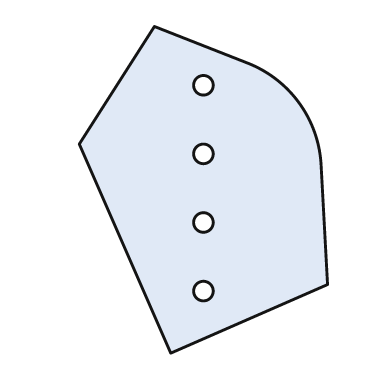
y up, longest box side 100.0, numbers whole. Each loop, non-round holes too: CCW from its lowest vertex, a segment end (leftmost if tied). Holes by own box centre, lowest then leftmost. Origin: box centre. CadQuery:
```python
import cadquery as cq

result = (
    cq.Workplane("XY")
    .moveTo(-10.0, -50.0)
    .lineTo(38.0, -29.0)
    .lineTo(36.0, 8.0)
    .threePointArc((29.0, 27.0), (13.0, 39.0))
    .lineTo(-15.0, 50.0)
    .lineTo(-38.0, 14.0)
    .close()
    .moveTo(0.0, -31.0)
    .circle(3.0)
    .moveTo(0.0, -10.0)
    .circle(3.0)
    .moveTo(0.0, 11.0)
    .circle(3.0)
    .moveTo(0.0, 32.0)
    .circle(3.0)
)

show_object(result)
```